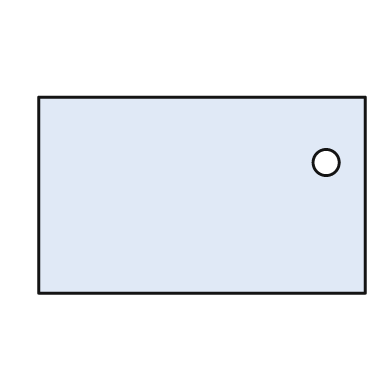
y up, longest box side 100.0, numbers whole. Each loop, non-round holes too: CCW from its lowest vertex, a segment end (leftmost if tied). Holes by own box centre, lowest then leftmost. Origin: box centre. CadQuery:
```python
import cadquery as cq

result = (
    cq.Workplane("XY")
    .moveTo(-50.0, -30.0)
    .lineTo(50.0, -30.0)
    .lineTo(50.0, 30.0)
    .lineTo(-50.0, 30.0)
    .close()
    .moveTo(38.0, 10.0)
    .circle(4.0)
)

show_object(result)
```